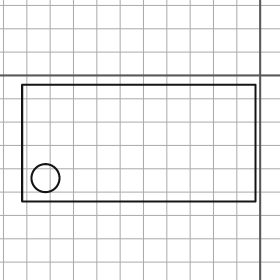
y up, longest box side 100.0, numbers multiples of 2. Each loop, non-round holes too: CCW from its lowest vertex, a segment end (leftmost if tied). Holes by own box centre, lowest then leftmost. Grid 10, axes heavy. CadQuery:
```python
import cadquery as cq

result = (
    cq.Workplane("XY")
    .moveTo(-102.0, -54.0)
    .lineTo(-2.0, -54.0)
    .lineTo(-2.0, -4.0)
    .lineTo(-102.0, -4.0)
    .close()
    .moveTo(-92.0, -44.0)
    .circle(6.0)
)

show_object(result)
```